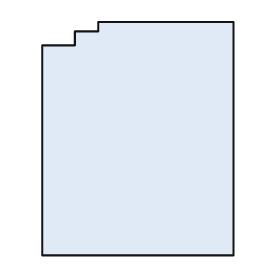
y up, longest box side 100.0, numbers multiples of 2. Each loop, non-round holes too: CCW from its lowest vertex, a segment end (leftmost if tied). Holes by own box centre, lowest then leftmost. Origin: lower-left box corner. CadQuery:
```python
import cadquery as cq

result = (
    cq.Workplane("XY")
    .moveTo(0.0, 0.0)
    .lineTo(82.0, 0.0)
    .lineTo(82.0, 100.0)
    .lineTo(24.0, 100.0)
    .lineTo(24.0, 96.0)
    .lineTo(14.0, 96.0)
    .lineTo(14.0, 90.0)
    .lineTo(0.0, 90.0)
    .close()
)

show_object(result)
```